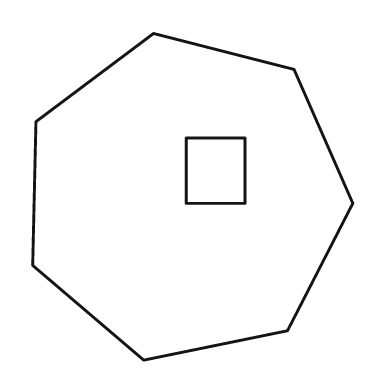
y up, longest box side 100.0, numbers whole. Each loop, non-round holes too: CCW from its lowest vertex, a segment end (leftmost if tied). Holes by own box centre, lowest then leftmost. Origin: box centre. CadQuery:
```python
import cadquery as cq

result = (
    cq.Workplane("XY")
    .moveTo(-15.0, -50.0)
    .lineTo(29.0, -41.0)
    .lineTo(49.0, -2.0)
    .lineTo(31.0, 39.0)
    .lineTo(-12.0, 50.0)
    .lineTo(-48.0, 23.0)
    .lineTo(-49.0, -21.0)
    .close()
    .moveTo(-2.0, -2.0)
    .lineTo(16.0, -2.0)
    .lineTo(16.0, 18.0)
    .lineTo(-2.0, 18.0)
    .close()
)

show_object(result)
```